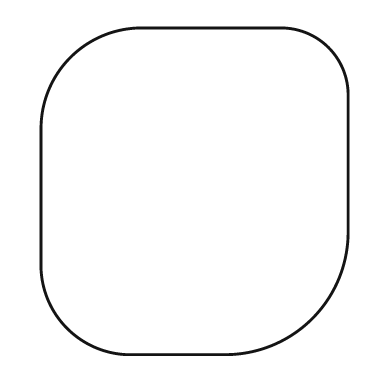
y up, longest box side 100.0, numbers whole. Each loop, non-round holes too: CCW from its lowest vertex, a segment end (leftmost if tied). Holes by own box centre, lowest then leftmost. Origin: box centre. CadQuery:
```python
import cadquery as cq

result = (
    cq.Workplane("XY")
    .moveTo(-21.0, -50.0)
    .lineTo(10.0, -50.0)
    .threePointArc((36.0, -39.0), (47.0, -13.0))
    .lineTo(47.0, 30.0)
    .threePointArc((41.0, 44.0), (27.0, 50.0))
    .lineTo(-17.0, 50.0)
    .threePointArc((-38.0, 41.0), (-47.0, 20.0))
    .lineTo(-47.0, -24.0)
    .threePointArc((-39.0, -42.0), (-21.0, -50.0))
    .close()
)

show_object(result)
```